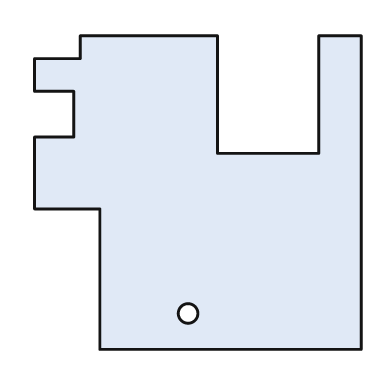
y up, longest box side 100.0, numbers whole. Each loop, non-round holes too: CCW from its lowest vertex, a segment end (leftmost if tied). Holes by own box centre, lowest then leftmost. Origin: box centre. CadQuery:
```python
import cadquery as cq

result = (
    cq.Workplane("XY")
    .moveTo(-30.0, -48.0)
    .lineTo(50.0, -48.0)
    .lineTo(50.0, 48.0)
    .lineTo(37.0, 48.0)
    .lineTo(37.0, 12.0)
    .lineTo(6.0, 12.0)
    .lineTo(6.0, 48.0)
    .lineTo(-36.0, 48.0)
    .lineTo(-36.0, 41.0)
    .lineTo(-50.0, 41.0)
    .lineTo(-50.0, 31.0)
    .lineTo(-38.0, 31.0)
    .lineTo(-38.0, 17.0)
    .lineTo(-50.0, 17.0)
    .lineTo(-50.0, -5.0)
    .lineTo(-30.0, -5.0)
    .close()
    .moveTo(-3.0, -37.0)
    .circle(3.0)
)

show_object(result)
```